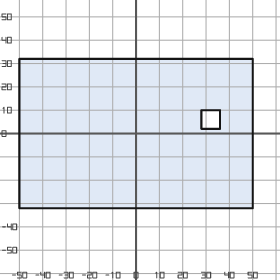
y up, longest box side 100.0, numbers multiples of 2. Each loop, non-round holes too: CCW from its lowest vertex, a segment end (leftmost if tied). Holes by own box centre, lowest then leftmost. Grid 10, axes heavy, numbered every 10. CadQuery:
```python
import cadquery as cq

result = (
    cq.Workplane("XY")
    .moveTo(-50.0, -32.0)
    .lineTo(50.0, -32.0)
    .lineTo(50.0, 32.0)
    .lineTo(-50.0, 32.0)
    .close()
    .moveTo(28.0, 2.0)
    .lineTo(36.0, 2.0)
    .lineTo(36.0, 10.0)
    .lineTo(28.0, 10.0)
    .close()
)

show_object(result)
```